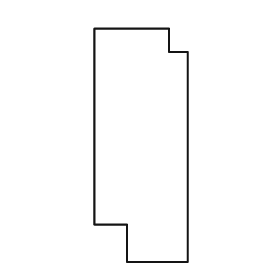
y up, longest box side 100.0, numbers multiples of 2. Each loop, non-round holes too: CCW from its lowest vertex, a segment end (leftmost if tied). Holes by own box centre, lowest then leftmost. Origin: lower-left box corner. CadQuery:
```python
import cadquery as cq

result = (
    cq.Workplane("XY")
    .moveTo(14.0, 0.0)
    .lineTo(40.0, 0.0)
    .lineTo(40.0, 90.0)
    .lineTo(32.0, 90.0)
    .lineTo(32.0, 100.0)
    .lineTo(0.0, 100.0)
    .lineTo(0.0, 16.0)
    .lineTo(14.0, 16.0)
    .close()
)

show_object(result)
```